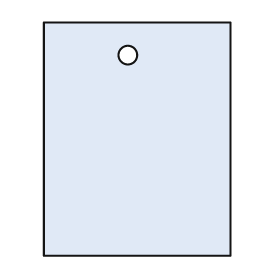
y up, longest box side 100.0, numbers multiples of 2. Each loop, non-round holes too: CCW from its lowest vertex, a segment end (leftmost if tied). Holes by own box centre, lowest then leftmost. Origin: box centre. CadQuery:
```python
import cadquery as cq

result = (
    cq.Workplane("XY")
    .moveTo(-40.0, -50.0)
    .lineTo(40.0, -50.0)
    .lineTo(40.0, 50.0)
    .lineTo(-40.0, 50.0)
    .close()
    .moveTo(-4.0, 36.0)
    .circle(4.0)
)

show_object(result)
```